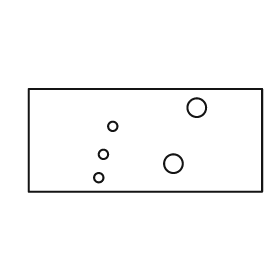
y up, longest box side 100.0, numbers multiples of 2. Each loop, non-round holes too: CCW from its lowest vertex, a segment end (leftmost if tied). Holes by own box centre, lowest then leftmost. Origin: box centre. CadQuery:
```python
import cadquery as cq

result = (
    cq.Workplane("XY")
    .moveTo(-50.0, -22.0)
    .lineTo(50.0, -22.0)
    .lineTo(50.0, 22.0)
    .lineTo(-50.0, 22.0)
    .close()
    .moveTo(-20.0, -16.0)
    .circle(2.0)
    .moveTo(12.0, -10.0)
    .circle(4.0)
    .moveTo(-18.0, -6.0)
    .circle(2.0)
    .moveTo(-14.0, 6.0)
    .circle(2.0)
    .moveTo(22.0, 14.0)
    .circle(4.0)
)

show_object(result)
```